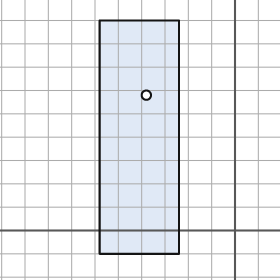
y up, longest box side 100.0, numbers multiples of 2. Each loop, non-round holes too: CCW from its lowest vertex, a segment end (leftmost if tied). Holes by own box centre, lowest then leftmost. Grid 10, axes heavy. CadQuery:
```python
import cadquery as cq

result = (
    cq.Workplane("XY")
    .moveTo(-58.0, -10.0)
    .lineTo(-24.0, -10.0)
    .lineTo(-24.0, 90.0)
    .lineTo(-58.0, 90.0)
    .close()
    .moveTo(-38.0, 58.0)
    .circle(2.0)
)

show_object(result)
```